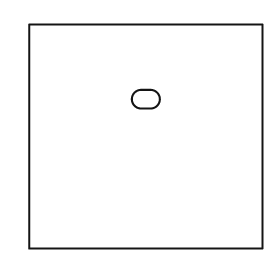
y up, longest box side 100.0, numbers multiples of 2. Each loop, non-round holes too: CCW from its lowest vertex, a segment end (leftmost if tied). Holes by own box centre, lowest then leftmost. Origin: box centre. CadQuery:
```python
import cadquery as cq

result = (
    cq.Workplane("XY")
    .moveTo(-50.0, -48.0)
    .lineTo(50.0, -48.0)
    .lineTo(50.0, 48.0)
    .lineTo(-50.0, 48.0)
    .close()
    .moveTo(-2.0, 12.0)
    .lineTo(2.0, 12.0)
    .threePointArc((6.0, 16.0), (2.0, 20.0))
    .lineTo(-2.0, 20.0)
    .threePointArc((-6.0, 16.0), (-2.0, 12.0))
    .close()
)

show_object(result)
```